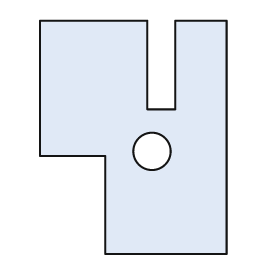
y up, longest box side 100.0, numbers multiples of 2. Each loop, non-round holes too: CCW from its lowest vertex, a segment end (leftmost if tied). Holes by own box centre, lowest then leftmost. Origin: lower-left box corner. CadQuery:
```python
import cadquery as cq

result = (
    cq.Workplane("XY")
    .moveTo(28.0, 0.0)
    .lineTo(80.0, 0.0)
    .lineTo(80.0, 100.0)
    .lineTo(58.0, 100.0)
    .lineTo(58.0, 62.0)
    .lineTo(46.0, 62.0)
    .lineTo(46.0, 100.0)
    .lineTo(0.0, 100.0)
    .lineTo(0.0, 42.0)
    .lineTo(28.0, 42.0)
    .close()
    .moveTo(48.0, 44.0)
    .circle(8.0)
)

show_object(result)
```